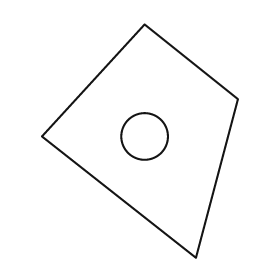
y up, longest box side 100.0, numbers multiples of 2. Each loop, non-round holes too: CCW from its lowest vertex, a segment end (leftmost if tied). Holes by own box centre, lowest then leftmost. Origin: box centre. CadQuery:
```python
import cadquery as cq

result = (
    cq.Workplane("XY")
    .moveTo(24.0, -50.0)
    .lineTo(42.0, 18.0)
    .lineTo(2.0, 50.0)
    .lineTo(-42.0, 2.0)
    .close()
    .moveTo(2.0, 2.0)
    .circle(10.0)
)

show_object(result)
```